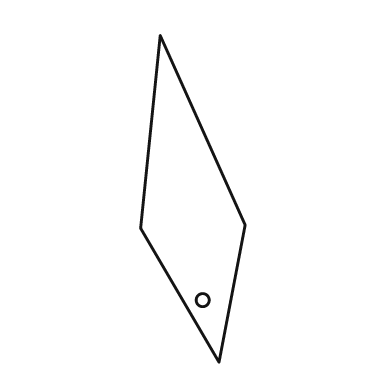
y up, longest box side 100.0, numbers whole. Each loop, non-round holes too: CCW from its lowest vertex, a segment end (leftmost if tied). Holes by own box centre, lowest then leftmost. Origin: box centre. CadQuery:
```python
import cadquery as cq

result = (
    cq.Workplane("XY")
    .moveTo(8.0, -50.0)
    .lineTo(16.0, -8.0)
    .lineTo(-10.0, 50.0)
    .lineTo(-16.0, -9.0)
    .close()
    .moveTo(3.0, -31.0)
    .circle(2.0)
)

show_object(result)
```